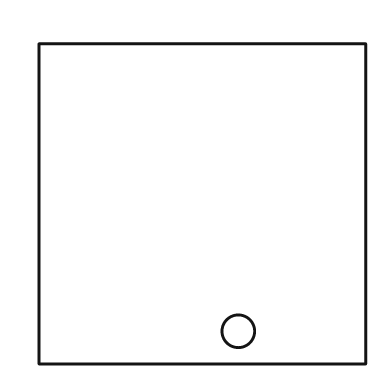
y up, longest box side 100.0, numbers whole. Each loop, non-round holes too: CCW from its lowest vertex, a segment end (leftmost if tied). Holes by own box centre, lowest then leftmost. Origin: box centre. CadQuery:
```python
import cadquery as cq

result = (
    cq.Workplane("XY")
    .moveTo(-50.0, -49.0)
    .lineTo(50.0, -49.0)
    .lineTo(50.0, 49.0)
    .lineTo(-50.0, 49.0)
    .close()
    .moveTo(11.0, -39.0)
    .circle(5.0)
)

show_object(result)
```